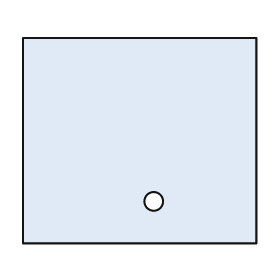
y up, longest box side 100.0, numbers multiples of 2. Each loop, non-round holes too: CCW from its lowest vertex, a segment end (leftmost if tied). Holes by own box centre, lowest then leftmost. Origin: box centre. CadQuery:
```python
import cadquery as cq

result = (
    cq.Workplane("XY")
    .moveTo(-50.0, -44.0)
    .lineTo(50.0, -44.0)
    .lineTo(50.0, 44.0)
    .lineTo(-50.0, 44.0)
    .close()
    .moveTo(6.0, -26.0)
    .circle(4.0)
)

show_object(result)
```